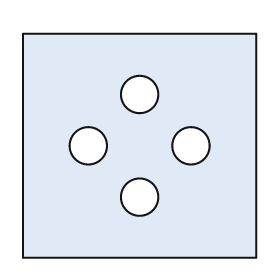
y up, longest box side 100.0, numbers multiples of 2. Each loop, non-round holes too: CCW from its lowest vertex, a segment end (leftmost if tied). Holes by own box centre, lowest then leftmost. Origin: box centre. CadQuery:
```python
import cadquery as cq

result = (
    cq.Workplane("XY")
    .moveTo(-50.0, -48.0)
    .lineTo(50.0, -48.0)
    .lineTo(50.0, 48.0)
    .lineTo(-50.0, 48.0)
    .close()
    .moveTo(0.0, -22.0)
    .circle(8.0)
    .moveTo(-22.0, 0.0)
    .circle(8.0)
    .moveTo(22.0, 0.0)
    .circle(8.0)
    .moveTo(0.0, 22.0)
    .circle(8.0)
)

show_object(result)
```